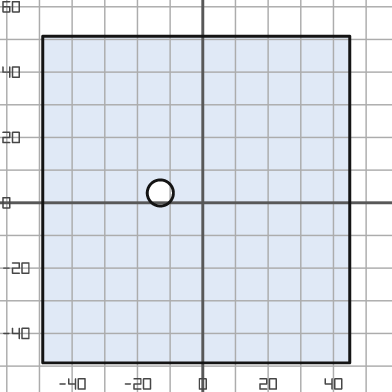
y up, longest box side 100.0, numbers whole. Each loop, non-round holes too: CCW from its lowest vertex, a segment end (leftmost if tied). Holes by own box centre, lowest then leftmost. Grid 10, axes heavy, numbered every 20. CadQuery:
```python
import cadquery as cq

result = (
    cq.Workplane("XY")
    .moveTo(-49.0, -49.0)
    .lineTo(45.0, -49.0)
    .lineTo(45.0, 51.0)
    .lineTo(-49.0, 51.0)
    .close()
    .moveTo(-13.0, 3.0)
    .circle(4.0)
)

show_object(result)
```